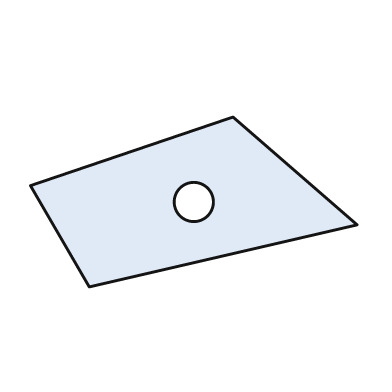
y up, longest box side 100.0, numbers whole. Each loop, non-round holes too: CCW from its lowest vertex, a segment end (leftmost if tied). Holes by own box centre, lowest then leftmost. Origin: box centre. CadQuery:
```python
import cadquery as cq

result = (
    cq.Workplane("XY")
    .moveTo(-32.0, -26.0)
    .lineTo(50.0, -7.0)
    .lineTo(12.0, 26.0)
    .lineTo(-50.0, 5.0)
    .close()
    .moveTo(0.0, 0.0)
    .circle(6.0)
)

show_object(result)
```